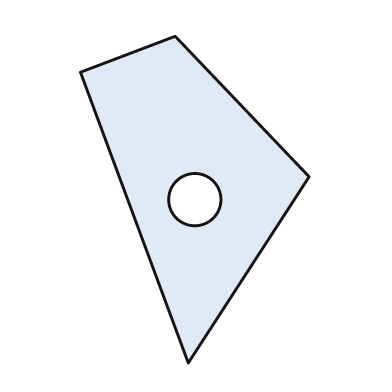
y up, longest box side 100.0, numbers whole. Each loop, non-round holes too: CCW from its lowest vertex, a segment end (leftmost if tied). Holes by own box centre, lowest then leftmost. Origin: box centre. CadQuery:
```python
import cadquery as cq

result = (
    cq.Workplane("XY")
    .moveTo(-2.0, -50.0)
    .lineTo(35.0, 7.0)
    .lineTo(-6.0, 50.0)
    .lineTo(-35.0, 39.0)
    .close()
    .moveTo(0.0, 0.0)
    .circle(8.0)
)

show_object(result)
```